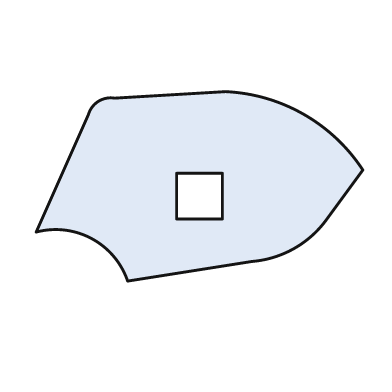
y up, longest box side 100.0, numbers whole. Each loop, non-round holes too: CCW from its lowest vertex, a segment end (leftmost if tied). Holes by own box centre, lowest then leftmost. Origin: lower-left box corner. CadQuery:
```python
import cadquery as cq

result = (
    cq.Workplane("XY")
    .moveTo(28.0, 0.0)
    .lineTo(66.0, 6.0)
    .threePointArc((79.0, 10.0), (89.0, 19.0))
    .lineTo(100.0, 34.0)
    .threePointArc((82.0, 51.0), (58.0, 58.0))
    .lineTo(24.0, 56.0)
    .threePointArc((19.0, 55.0), (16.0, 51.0))
    .lineTo(0.0, 15.0)
    .threePointArc((17.0, 13.0), (28.0, 0.0))
    .close()
    .moveTo(43.0, 19.0)
    .lineTo(57.0, 19.0)
    .lineTo(57.0, 33.0)
    .lineTo(43.0, 33.0)
    .close()
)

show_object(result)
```